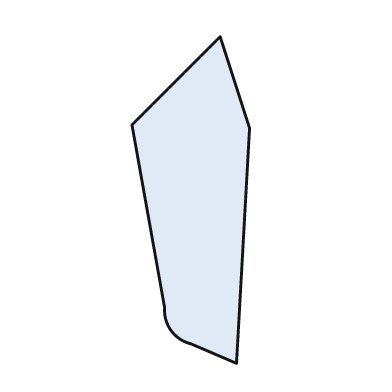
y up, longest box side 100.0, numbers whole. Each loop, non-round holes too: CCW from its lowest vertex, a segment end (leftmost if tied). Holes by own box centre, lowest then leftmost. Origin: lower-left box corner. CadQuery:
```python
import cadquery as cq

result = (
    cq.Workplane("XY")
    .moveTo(32.0, 0.0)
    .lineTo(36.0, 72.0)
    .lineTo(27.0, 100.0)
    .lineTo(0.0, 73.0)
    .lineTo(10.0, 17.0)
    .threePointArc((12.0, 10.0), (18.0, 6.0))
    .close()
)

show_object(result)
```